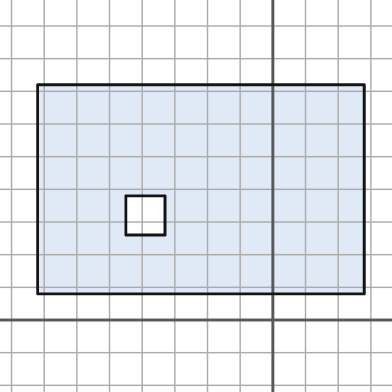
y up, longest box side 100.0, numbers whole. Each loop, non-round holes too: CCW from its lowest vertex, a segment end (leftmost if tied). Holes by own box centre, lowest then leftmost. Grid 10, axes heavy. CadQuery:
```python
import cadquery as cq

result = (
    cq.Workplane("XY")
    .moveTo(-72.0, 8.0)
    .lineTo(28.0, 8.0)
    .lineTo(28.0, 72.0)
    .lineTo(-72.0, 72.0)
    .close()
    .moveTo(-45.0, 26.0)
    .lineTo(-33.0, 26.0)
    .lineTo(-33.0, 38.0)
    .lineTo(-45.0, 38.0)
    .close()
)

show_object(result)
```